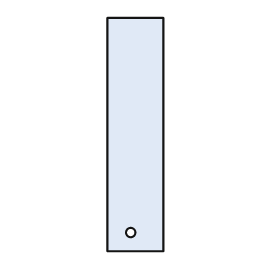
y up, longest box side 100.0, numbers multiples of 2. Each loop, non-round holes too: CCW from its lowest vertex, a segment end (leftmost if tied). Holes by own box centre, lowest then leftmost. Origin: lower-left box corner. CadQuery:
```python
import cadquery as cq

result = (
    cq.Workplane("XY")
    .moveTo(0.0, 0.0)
    .lineTo(24.0, 0.0)
    .lineTo(24.0, 100.0)
    .lineTo(0.0, 100.0)
    .close()
    .moveTo(10.0, 8.0)
    .circle(2.0)
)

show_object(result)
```